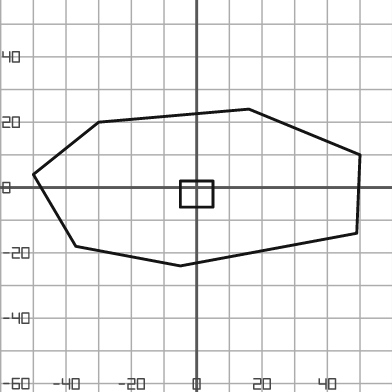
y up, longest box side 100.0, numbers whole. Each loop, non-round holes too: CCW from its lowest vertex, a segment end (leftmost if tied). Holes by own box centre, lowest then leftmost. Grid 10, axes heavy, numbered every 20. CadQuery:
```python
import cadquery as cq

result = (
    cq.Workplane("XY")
    .moveTo(-5.0, -24.0)
    .lineTo(49.0, -14.0)
    .lineTo(50.0, 10.0)
    .lineTo(16.0, 24.0)
    .lineTo(-30.0, 20.0)
    .lineTo(-50.0, 4.0)
    .lineTo(-37.0, -18.0)
    .close()
    .moveTo(-5.0, -6.0)
    .lineTo(5.0, -6.0)
    .lineTo(5.0, 2.0)
    .lineTo(-5.0, 2.0)
    .close()
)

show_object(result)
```